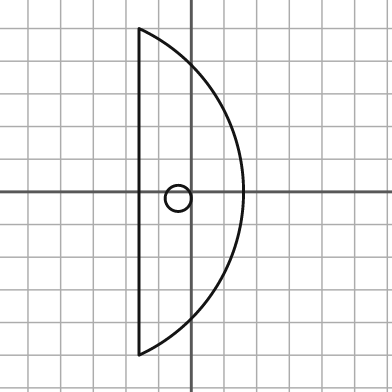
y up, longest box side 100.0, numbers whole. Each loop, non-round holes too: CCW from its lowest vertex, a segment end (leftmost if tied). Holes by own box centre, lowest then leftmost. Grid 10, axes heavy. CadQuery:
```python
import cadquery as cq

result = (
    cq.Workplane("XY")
    .moveTo(-16.0, -50.0)
    .threePointArc((16.0, 0.0), (-16.0, 50.0))
    .close()
    .moveTo(-4.0, -2.0)
    .circle(4.0)
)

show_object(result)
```